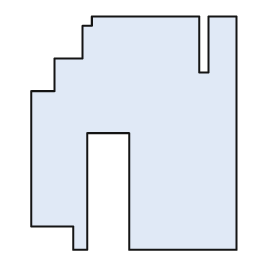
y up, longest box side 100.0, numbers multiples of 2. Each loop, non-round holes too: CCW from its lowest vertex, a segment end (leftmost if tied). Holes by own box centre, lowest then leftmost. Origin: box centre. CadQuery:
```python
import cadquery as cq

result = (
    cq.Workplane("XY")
    .moveTo(-26.0, -50.0)
    .lineTo(-20.0, -50.0)
    .lineTo(-20.0, 0.0)
    .lineTo(-2.0, 0.0)
    .lineTo(-2.0, -50.0)
    .lineTo(44.0, -50.0)
    .lineTo(44.0, 50.0)
    .lineTo(32.0, 50.0)
    .lineTo(32.0, 26.0)
    .lineTo(28.0, 26.0)
    .lineTo(28.0, 50.0)
    .lineTo(-18.0, 50.0)
    .lineTo(-18.0, 46.0)
    .lineTo(-22.0, 46.0)
    .lineTo(-22.0, 32.0)
    .lineTo(-34.0, 32.0)
    .lineTo(-34.0, 18.0)
    .lineTo(-44.0, 18.0)
    .lineTo(-44.0, -40.0)
    .lineTo(-26.0, -40.0)
    .close()
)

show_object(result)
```